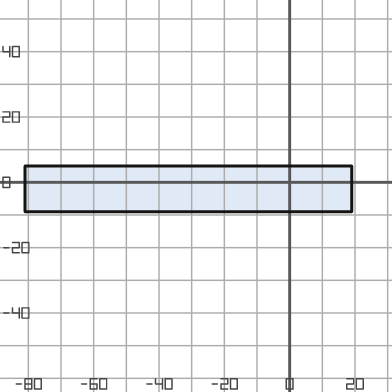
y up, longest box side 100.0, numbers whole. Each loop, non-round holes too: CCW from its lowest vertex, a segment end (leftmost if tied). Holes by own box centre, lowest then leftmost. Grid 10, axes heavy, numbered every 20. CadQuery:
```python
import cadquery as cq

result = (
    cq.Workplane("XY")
    .moveTo(-81.0, -9.0)
    .lineTo(19.0, -9.0)
    .lineTo(19.0, 5.0)
    .lineTo(-81.0, 5.0)
    .close()
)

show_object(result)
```